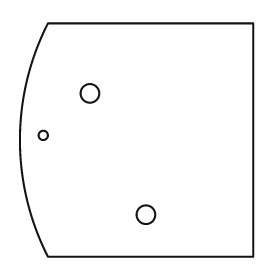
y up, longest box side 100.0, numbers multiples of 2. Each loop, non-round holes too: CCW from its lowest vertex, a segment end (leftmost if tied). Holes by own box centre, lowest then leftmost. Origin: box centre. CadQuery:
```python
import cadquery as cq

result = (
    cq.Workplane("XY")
    .moveTo(-38.0, -50.0)
    .lineTo(50.0, -50.0)
    .lineTo(50.0, 50.0)
    .lineTo(-38.0, 50.0)
    .threePointArc((-50.0, 0.0), (-38.0, -50.0))
    .close()
    .moveTo(4.0, -32.0)
    .circle(4.0)
    .moveTo(-40.0, 2.0)
    .circle(2.0)
    .moveTo(-20.0, 20.0)
    .circle(4.0)
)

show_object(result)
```